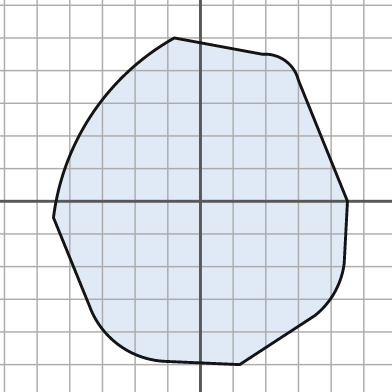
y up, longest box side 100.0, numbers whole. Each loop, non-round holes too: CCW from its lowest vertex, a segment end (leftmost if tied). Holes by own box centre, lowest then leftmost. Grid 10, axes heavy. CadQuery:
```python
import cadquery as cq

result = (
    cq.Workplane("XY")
    .moveTo(12.0, -50.0)
    .lineTo(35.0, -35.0)
    .threePointArc((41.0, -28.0), (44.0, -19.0))
    .lineTo(45.0, 0.0)
    .lineTo(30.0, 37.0)
    .threePointArc((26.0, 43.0), (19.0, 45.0))
    .lineTo(-8.0, 50.0)
    .threePointArc((-33.0, 27.0), (-45.0, -5.0))
    .lineTo(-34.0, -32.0)
    .threePointArc((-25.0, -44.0), (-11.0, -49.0))
    .close()
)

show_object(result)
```